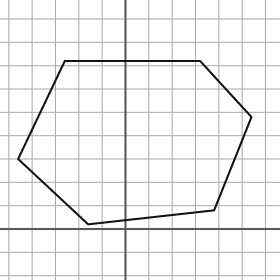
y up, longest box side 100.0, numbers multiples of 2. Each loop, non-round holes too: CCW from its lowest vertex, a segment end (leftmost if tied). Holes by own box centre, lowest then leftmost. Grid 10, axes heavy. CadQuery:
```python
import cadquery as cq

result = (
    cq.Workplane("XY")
    .moveTo(-16.0, 2.0)
    .lineTo(38.0, 8.0)
    .lineTo(54.0, 48.0)
    .lineTo(32.0, 72.0)
    .lineTo(-26.0, 72.0)
    .lineTo(-46.0, 30.0)
    .close()
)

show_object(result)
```